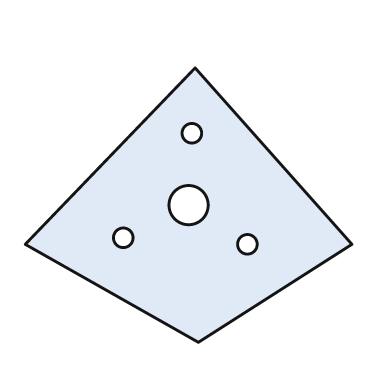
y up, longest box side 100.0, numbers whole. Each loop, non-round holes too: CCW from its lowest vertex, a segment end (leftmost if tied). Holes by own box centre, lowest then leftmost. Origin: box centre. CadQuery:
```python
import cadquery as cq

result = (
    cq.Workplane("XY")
    .moveTo(3.0, -42.0)
    .lineTo(50.0, -12.0)
    .lineTo(2.0, 42.0)
    .lineTo(-50.0, -12.0)
    .close()
    .moveTo(18.0, -12.0)
    .circle(3.0)
    .moveTo(-20.0, -10.0)
    .circle(3.0)
    .moveTo(0.0, 0.0)
    .circle(6.0)
    .moveTo(1.0, 22.0)
    .circle(3.0)
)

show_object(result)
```